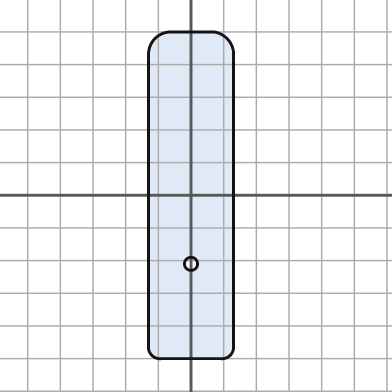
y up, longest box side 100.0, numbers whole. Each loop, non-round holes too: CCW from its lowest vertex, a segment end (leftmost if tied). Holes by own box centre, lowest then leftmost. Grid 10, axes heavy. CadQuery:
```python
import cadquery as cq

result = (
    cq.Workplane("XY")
    .moveTo(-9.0, -50.0)
    .lineTo(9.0, -50.0)
    .threePointArc((12.0, -49.0), (13.0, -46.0))
    .lineTo(13.0, 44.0)
    .threePointArc((11.0, 48.0), (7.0, 50.0))
    .lineTo(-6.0, 50.0)
    .threePointArc((-11.0, 48.0), (-13.0, 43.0))
    .lineTo(-13.0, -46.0)
    .threePointArc((-12.0, -49.0), (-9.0, -50.0))
    .close()
    .moveTo(0.0, -21.0)
    .circle(2.0)
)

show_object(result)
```